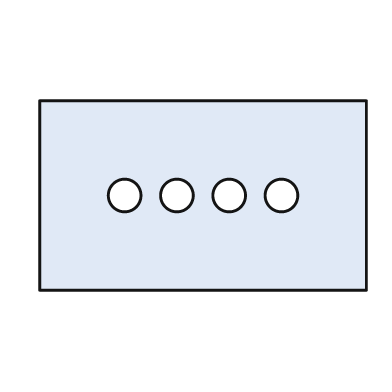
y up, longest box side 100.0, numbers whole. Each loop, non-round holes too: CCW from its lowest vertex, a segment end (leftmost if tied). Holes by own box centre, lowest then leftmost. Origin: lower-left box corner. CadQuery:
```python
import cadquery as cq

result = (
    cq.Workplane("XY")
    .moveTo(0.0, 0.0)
    .lineTo(100.0, 0.0)
    .lineTo(100.0, 58.0)
    .lineTo(0.0, 58.0)
    .close()
    .moveTo(26.0, 29.0)
    .circle(5.0)
    .moveTo(42.0, 29.0)
    .circle(5.0)
    .moveTo(58.0, 29.0)
    .circle(5.0)
    .moveTo(74.0, 29.0)
    .circle(5.0)
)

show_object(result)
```